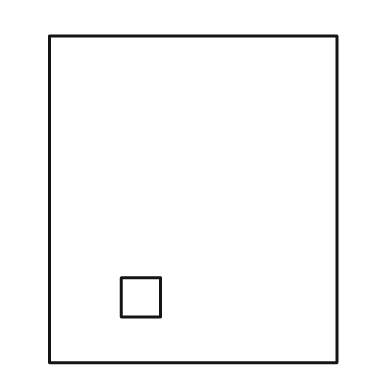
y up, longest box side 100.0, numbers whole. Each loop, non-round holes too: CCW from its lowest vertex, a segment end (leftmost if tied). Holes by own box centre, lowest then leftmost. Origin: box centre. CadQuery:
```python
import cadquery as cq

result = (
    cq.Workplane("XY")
    .moveTo(-44.0, -50.0)
    .lineTo(44.0, -50.0)
    .lineTo(44.0, 50.0)
    .lineTo(-44.0, 50.0)
    .close()
    .moveTo(-22.0, -36.0)
    .lineTo(-10.0, -36.0)
    .lineTo(-10.0, -24.0)
    .lineTo(-22.0, -24.0)
    .close()
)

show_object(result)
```